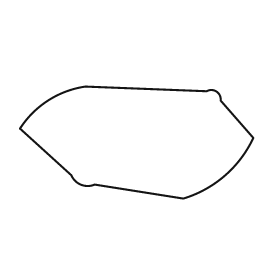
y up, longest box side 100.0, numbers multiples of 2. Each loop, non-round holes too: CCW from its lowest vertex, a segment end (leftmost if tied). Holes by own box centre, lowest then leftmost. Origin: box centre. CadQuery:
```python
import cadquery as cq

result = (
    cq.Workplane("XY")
    .moveTo(20.0, -24.0)
    .threePointArc((38.0, -14.0), (50.0, 2.0))
    .lineTo(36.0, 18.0)
    .threePointArc((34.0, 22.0), (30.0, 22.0))
    .lineTo(-22.0, 24.0)
    .threePointArc((-38.0, 18.0), (-50.0, 6.0))
    .lineTo(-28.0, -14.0)
    .threePointArc((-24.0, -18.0), (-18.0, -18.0))
    .close()
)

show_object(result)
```